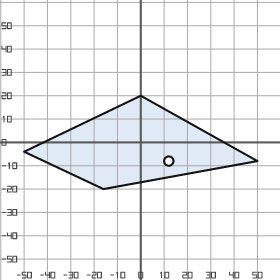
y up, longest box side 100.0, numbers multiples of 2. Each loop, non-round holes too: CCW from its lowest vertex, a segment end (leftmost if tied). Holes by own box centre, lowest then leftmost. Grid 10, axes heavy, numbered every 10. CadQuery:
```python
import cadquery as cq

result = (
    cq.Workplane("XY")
    .moveTo(-16.0, -20.0)
    .lineTo(50.0, -8.0)
    .lineTo(0.0, 20.0)
    .lineTo(-50.0, -4.0)
    .close()
    .moveTo(12.0, -8.0)
    .circle(2.0)
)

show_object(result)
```